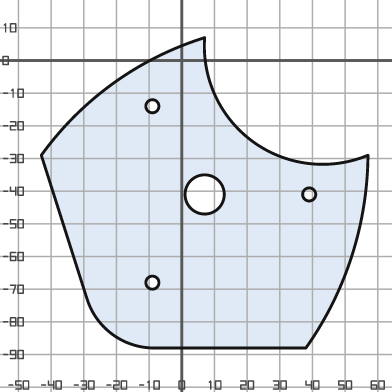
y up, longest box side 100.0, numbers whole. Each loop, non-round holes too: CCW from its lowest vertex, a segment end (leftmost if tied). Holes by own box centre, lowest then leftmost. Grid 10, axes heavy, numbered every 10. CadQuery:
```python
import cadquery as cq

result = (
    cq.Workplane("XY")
    .moveTo(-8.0, -88.0)
    .lineTo(38.0, -88.0)
    .threePointArc((52.0, -60.0), (57.0, -29.0))
    .threePointArc((22.0, -25.0), (7.0, 7.0))
    .threePointArc((-21.0, -7.0), (-43.0, -29.0))
    .lineTo(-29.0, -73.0)
    .threePointArc((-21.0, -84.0), (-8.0, -88.0))
    .close()
    .moveTo(-9.0, -68.0)
    .circle(2.0)
    .moveTo(7.0, -41.0)
    .circle(6.0)
    .moveTo(39.0, -41.0)
    .circle(2.0)
    .moveTo(-9.0, -14.0)
    .circle(2.0)
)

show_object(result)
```